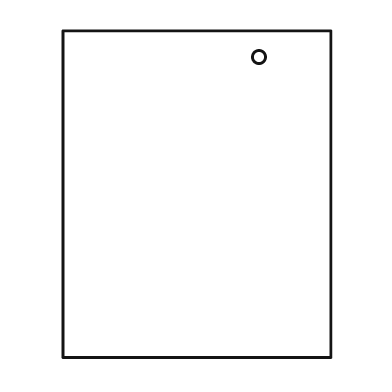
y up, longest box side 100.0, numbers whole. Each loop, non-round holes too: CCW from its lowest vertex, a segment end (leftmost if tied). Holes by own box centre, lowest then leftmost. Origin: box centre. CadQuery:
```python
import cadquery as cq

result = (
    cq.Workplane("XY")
    .moveTo(-41.0, -50.0)
    .lineTo(41.0, -50.0)
    .lineTo(41.0, 50.0)
    .lineTo(-41.0, 50.0)
    .close()
    .moveTo(19.0, 42.0)
    .circle(2.0)
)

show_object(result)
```